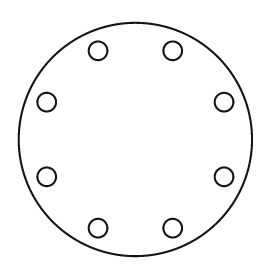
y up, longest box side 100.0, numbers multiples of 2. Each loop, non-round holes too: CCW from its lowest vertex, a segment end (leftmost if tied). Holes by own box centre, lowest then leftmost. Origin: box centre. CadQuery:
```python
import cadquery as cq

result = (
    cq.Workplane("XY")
    .moveTo(0.0, 0.0)
    .circle(50.0)
    .moveTo(-16.0, -38.0)
    .circle(4.0)
    .moveTo(16.0, -38.0)
    .circle(4.0)
    .moveTo(-38.0, -16.0)
    .circle(4.0)
    .moveTo(38.0, -16.0)
    .circle(4.0)
    .moveTo(-38.0, 16.0)
    .circle(4.0)
    .moveTo(38.0, 16.0)
    .circle(4.0)
    .moveTo(-16.0, 38.0)
    .circle(4.0)
    .moveTo(16.0, 38.0)
    .circle(4.0)
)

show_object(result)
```